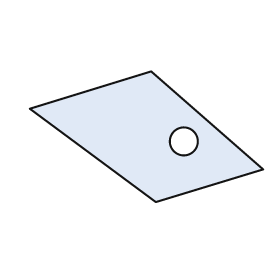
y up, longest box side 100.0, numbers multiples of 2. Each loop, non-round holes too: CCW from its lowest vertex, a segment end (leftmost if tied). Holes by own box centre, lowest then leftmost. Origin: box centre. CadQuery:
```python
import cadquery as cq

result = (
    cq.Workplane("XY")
    .moveTo(4.0, -28.0)
    .lineTo(50.0, -14.0)
    .lineTo(2.0, 28.0)
    .lineTo(-50.0, 12.0)
    .close()
    .moveTo(16.0, -2.0)
    .circle(6.0)
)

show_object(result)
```